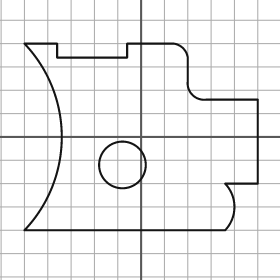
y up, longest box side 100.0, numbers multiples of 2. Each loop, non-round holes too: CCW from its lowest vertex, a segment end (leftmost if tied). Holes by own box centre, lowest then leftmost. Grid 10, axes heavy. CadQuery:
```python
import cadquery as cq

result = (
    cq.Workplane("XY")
    .moveTo(-50.0, -40.0)
    .lineTo(36.0, -40.0)
    .threePointArc((40.0, -30.0), (36.0, -20.0))
    .lineTo(50.0, -20.0)
    .lineTo(50.0, 16.0)
    .lineTo(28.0, 16.0)
    .threePointArc((22.0, 18.0), (20.0, 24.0))
    .lineTo(20.0, 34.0)
    .threePointArc((18.0, 38.0), (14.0, 40.0))
    .lineTo(-6.0, 40.0)
    .lineTo(-6.0, 34.0)
    .lineTo(-36.0, 34.0)
    .lineTo(-36.0, 40.0)
    .lineTo(-50.0, 40.0)
    .threePointArc((-34.0, 0.0), (-50.0, -40.0))
    .close()
    .moveTo(-8.0, -12.0)
    .circle(10.0)
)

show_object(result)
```